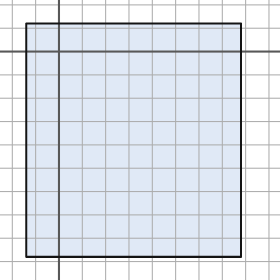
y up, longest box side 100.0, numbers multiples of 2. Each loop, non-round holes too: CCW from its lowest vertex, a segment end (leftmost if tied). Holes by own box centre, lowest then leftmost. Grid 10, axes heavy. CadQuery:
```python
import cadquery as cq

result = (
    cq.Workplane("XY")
    .moveTo(-14.0, -88.0)
    .lineTo(78.0, -88.0)
    .lineTo(78.0, 12.0)
    .lineTo(-14.0, 12.0)
    .close()
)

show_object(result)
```